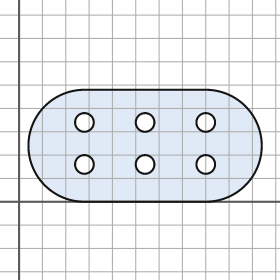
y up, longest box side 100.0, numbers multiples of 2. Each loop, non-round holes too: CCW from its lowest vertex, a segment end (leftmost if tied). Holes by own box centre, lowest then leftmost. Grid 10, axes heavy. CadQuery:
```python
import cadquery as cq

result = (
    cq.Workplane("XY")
    .moveTo(28.0, 0.0)
    .lineTo(80.0, 0.0)
    .threePointArc((104.0, 24.0), (80.0, 48.0))
    .lineTo(28.0, 48.0)
    .threePointArc((4.0, 24.0), (28.0, 0.0))
    .close()
    .moveTo(28.0, 16.0)
    .circle(4.0)
    .moveTo(54.0, 16.0)
    .circle(4.0)
    .moveTo(80.0, 16.0)
    .circle(4.0)
    .moveTo(28.0, 34.0)
    .circle(4.0)
    .moveTo(54.0, 34.0)
    .circle(4.0)
    .moveTo(80.0, 34.0)
    .circle(4.0)
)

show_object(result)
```